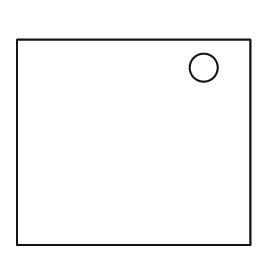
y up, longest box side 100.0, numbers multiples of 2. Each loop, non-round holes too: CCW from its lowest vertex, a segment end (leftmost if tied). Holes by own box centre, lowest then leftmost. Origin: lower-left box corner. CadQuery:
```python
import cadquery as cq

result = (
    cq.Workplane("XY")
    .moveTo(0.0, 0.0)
    .lineTo(100.0, 0.0)
    .lineTo(100.0, 88.0)
    .lineTo(0.0, 88.0)
    .close()
    .moveTo(80.0, 76.0)
    .circle(6.0)
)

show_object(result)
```